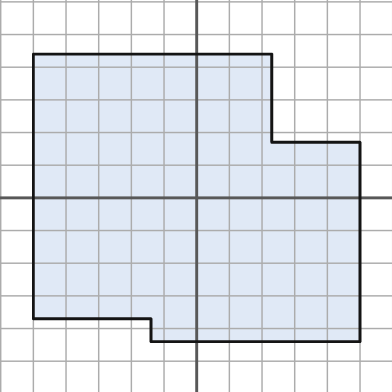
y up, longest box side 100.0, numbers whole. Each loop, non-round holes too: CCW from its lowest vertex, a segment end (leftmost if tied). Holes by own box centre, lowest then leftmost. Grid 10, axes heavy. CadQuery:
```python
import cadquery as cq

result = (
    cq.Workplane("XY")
    .moveTo(-14.0, -44.0)
    .lineTo(50.0, -44.0)
    .lineTo(50.0, 17.0)
    .lineTo(23.0, 17.0)
    .lineTo(23.0, 44.0)
    .lineTo(-50.0, 44.0)
    .lineTo(-50.0, -37.0)
    .lineTo(-14.0, -37.0)
    .close()
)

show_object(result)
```